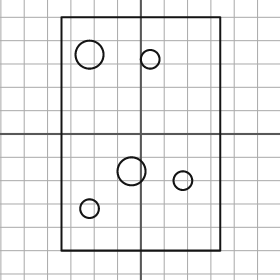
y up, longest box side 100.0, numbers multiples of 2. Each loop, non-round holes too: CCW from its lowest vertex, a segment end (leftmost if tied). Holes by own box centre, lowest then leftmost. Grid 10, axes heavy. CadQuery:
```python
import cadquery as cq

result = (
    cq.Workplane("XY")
    .moveTo(-34.0, -50.0)
    .lineTo(34.0, -50.0)
    .lineTo(34.0, 50.0)
    .lineTo(-34.0, 50.0)
    .close()
    .moveTo(-22.0, -32.0)
    .circle(4.0)
    .moveTo(18.0, -20.0)
    .circle(4.0)
    .moveTo(-4.0, -16.0)
    .circle(6.0)
    .moveTo(4.0, 32.0)
    .circle(4.0)
    .moveTo(-22.0, 34.0)
    .circle(6.0)
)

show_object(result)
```